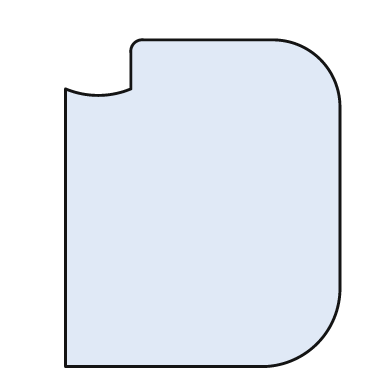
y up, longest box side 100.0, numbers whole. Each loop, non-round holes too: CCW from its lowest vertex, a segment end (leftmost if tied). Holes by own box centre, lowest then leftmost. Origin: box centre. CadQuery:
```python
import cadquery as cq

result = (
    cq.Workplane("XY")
    .moveTo(-42.0, -50.0)
    .lineTo(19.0, -50.0)
    .threePointArc((35.0, -43.0), (42.0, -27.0))
    .lineTo(42.0, 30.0)
    .threePointArc((36.0, 44.0), (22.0, 50.0))
    .lineTo(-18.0, 50.0)
    .threePointArc((-21.0, 49.0), (-22.0, 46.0))
    .lineTo(-22.0, 35.0)
    .threePointArc((-32.0, 33.0), (-42.0, 35.0))
    .close()
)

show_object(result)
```